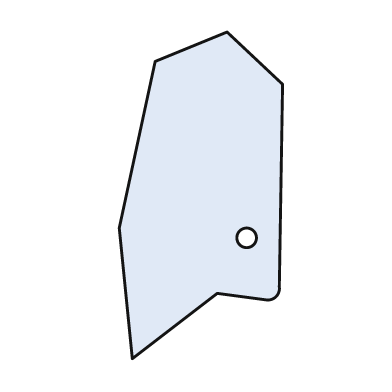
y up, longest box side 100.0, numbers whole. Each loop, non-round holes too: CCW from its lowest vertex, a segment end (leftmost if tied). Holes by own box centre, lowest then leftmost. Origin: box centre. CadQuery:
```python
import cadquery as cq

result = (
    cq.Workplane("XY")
    .moveTo(-21.0, -50.0)
    .lineTo(5.0, -30.0)
    .lineTo(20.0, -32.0)
    .threePointArc((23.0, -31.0), (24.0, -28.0))
    .lineTo(25.0, 34.0)
    .lineTo(8.0, 50.0)
    .lineTo(-14.0, 41.0)
    .lineTo(-25.0, -10.0)
    .close()
    .moveTo(14.0, -13.0)
    .circle(3.0)
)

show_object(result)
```